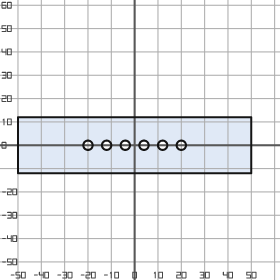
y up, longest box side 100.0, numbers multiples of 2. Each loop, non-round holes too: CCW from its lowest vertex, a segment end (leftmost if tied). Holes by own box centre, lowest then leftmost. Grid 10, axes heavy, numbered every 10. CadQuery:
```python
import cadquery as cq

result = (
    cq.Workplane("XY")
    .moveTo(-50.0, -12.0)
    .lineTo(50.0, -12.0)
    .lineTo(50.0, 12.0)
    .lineTo(-50.0, 12.0)
    .close()
    .moveTo(-20.0, 0.0)
    .circle(2.0)
    .moveTo(-12.0, 0.0)
    .circle(2.0)
    .moveTo(-4.0, 0.0)
    .circle(2.0)
    .moveTo(4.0, 0.0)
    .circle(2.0)
    .moveTo(12.0, 0.0)
    .circle(2.0)
    .moveTo(20.0, 0.0)
    .circle(2.0)
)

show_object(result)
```